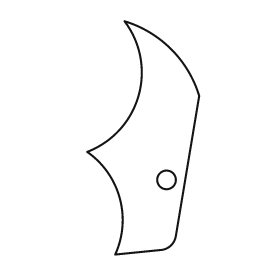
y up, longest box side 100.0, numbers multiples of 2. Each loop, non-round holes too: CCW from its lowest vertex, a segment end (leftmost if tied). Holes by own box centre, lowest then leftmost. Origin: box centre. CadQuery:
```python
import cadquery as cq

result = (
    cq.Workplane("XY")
    .moveTo(-12.0, -50.0)
    .lineTo(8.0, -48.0)
    .threePointArc((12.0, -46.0), (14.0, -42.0))
    .lineTo(24.0, 18.0)
    .threePointArc((12.0, 38.0), (-8.0, 50.0))
    .threePointArc((-2.0, 18.0), (-24.0, -6.0))
    .threePointArc((-10.0, -26.0), (-12.0, -50.0))
    .close()
    .moveTo(10.0, -18.0)
    .circle(4.0)
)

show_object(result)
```